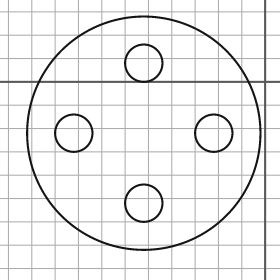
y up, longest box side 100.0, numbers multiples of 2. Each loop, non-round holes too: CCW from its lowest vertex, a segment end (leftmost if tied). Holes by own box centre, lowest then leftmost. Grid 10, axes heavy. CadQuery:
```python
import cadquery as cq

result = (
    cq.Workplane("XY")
    .moveTo(-52.0, -22.0)
    .circle(50.0)
    .moveTo(-52.0, -52.0)
    .circle(8.0)
    .moveTo(-82.0, -22.0)
    .circle(8.0)
    .moveTo(-22.0, -22.0)
    .circle(8.0)
    .moveTo(-52.0, 8.0)
    .circle(8.0)
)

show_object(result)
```